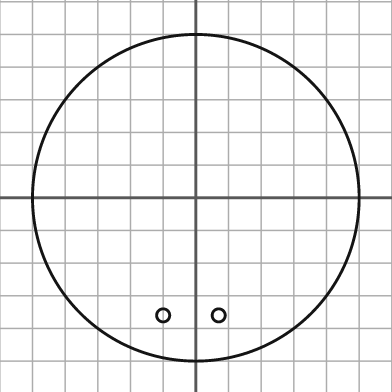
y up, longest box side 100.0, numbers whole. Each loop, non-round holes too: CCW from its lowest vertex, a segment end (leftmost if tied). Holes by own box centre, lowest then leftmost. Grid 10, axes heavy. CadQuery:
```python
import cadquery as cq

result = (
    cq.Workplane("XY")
    .moveTo(0.0, 0.0)
    .circle(50.0)
    .moveTo(-10.0, -36.0)
    .circle(2.0)
    .moveTo(7.0, -36.0)
    .circle(2.0)
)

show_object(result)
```